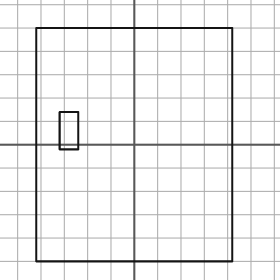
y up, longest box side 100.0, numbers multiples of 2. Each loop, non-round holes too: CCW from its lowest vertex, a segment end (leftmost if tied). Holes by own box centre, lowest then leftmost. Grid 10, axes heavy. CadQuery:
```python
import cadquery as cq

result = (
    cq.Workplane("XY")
    .moveTo(-42.0, -50.0)
    .lineTo(42.0, -50.0)
    .lineTo(42.0, 50.0)
    .lineTo(-42.0, 50.0)
    .close()
    .moveTo(-32.0, -2.0)
    .lineTo(-24.0, -2.0)
    .lineTo(-24.0, 14.0)
    .lineTo(-32.0, 14.0)
    .close()
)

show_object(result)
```